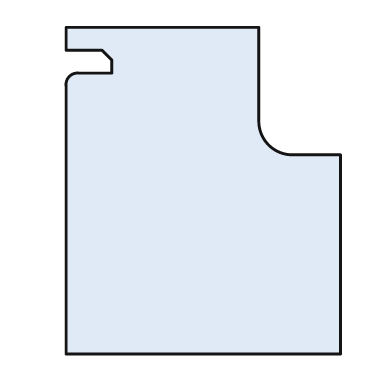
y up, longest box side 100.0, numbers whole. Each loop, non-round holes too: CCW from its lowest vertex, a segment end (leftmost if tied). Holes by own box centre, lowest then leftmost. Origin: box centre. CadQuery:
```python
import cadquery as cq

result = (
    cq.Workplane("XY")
    .moveTo(-42.0, -50.0)
    .lineTo(42.0, -50.0)
    .lineTo(42.0, 11.0)
    .lineTo(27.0, 11.0)
    .threePointArc((20.0, 14.0), (17.0, 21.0))
    .lineTo(17.0, 50.0)
    .lineTo(-42.0, 50.0)
    .lineTo(-42.0, 43.0)
    .lineTo(-31.0, 43.0)
    .lineTo(-28.0, 40.0)
    .lineTo(-28.0, 36.0)
    .lineTo(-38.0, 36.0)
    .threePointArc((-41.0, 35.0), (-42.0, 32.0))
    .close()
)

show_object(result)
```